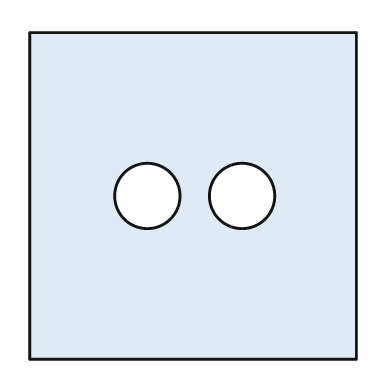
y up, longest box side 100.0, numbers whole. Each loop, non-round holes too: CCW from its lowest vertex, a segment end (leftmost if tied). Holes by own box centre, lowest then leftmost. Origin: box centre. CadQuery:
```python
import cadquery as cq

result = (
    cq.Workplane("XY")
    .moveTo(-50.0, -50.0)
    .lineTo(50.0, -50.0)
    .lineTo(50.0, 50.0)
    .lineTo(-50.0, 50.0)
    .close()
    .moveTo(-14.0, 0.0)
    .circle(10.0)
    .moveTo(15.0, 0.0)
    .circle(10.0)
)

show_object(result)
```